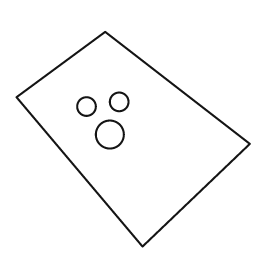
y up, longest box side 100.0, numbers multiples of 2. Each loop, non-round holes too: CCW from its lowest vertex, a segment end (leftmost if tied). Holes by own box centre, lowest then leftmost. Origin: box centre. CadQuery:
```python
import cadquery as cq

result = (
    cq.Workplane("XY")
    .moveTo(4.0, -46.0)
    .lineTo(50.0, -2.0)
    .lineTo(-12.0, 46.0)
    .lineTo(-50.0, 18.0)
    .close()
    .moveTo(-10.0, 2.0)
    .circle(6.0)
    .moveTo(-20.0, 14.0)
    .circle(4.0)
    .moveTo(-6.0, 16.0)
    .circle(4.0)
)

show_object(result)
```